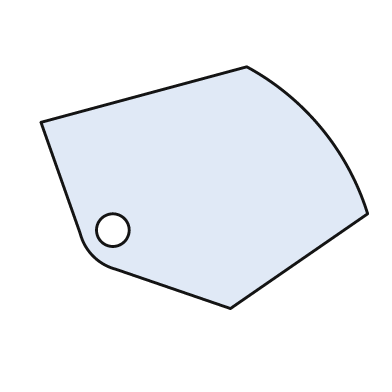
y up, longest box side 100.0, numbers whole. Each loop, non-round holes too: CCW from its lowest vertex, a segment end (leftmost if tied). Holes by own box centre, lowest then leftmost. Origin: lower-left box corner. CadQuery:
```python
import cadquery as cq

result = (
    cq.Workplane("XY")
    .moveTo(58.0, 0.0)
    .lineTo(100.0, 29.0)
    .threePointArc((86.0, 55.0), (63.0, 74.0))
    .lineTo(0.0, 57.0)
    .lineTo(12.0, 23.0)
    .threePointArc((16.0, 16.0), (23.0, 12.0))
    .close()
    .moveTo(22.0, 24.0)
    .circle(5.0)
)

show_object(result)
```